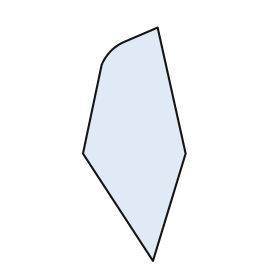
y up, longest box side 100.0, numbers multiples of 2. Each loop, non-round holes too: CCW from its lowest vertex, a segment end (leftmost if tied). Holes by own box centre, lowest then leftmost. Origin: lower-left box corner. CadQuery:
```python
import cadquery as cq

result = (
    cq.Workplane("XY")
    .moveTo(30.0, 0.0)
    .lineTo(44.0, 46.0)
    .lineTo(32.0, 100.0)
    .lineTo(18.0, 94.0)
    .threePointArc((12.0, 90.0), (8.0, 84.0))
    .lineTo(0.0, 46.0)
    .close()
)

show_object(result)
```